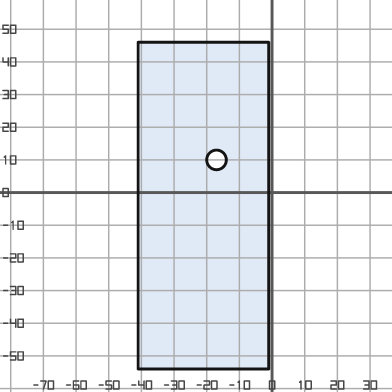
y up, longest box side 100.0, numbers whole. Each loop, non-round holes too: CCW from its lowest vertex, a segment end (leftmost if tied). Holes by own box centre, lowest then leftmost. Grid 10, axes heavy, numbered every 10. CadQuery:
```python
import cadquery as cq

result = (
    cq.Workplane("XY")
    .moveTo(-41.0, -54.0)
    .lineTo(-1.0, -54.0)
    .lineTo(-1.0, 46.0)
    .lineTo(-41.0, 46.0)
    .close()
    .moveTo(-17.0, 10.0)
    .circle(3.0)
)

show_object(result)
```